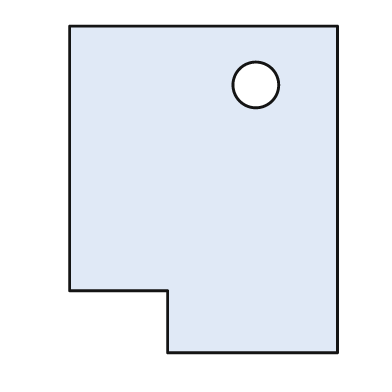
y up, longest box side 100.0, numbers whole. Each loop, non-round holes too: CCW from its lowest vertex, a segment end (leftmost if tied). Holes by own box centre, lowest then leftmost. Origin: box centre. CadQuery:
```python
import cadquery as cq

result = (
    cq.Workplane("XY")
    .moveTo(-11.0, -50.0)
    .lineTo(41.0, -50.0)
    .lineTo(41.0, 50.0)
    .lineTo(-41.0, 50.0)
    .lineTo(-41.0, -31.0)
    .lineTo(-11.0, -31.0)
    .close()
    .moveTo(16.0, 32.0)
    .circle(7.0)
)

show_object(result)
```